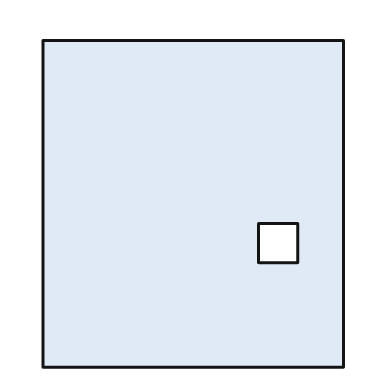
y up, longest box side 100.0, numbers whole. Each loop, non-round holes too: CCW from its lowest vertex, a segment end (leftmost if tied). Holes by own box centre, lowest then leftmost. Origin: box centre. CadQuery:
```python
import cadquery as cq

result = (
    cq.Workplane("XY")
    .moveTo(-46.0, -50.0)
    .lineTo(46.0, -50.0)
    .lineTo(46.0, 50.0)
    .lineTo(-46.0, 50.0)
    .close()
    .moveTo(20.0, -18.0)
    .lineTo(32.0, -18.0)
    .lineTo(32.0, -6.0)
    .lineTo(20.0, -6.0)
    .close()
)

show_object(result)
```